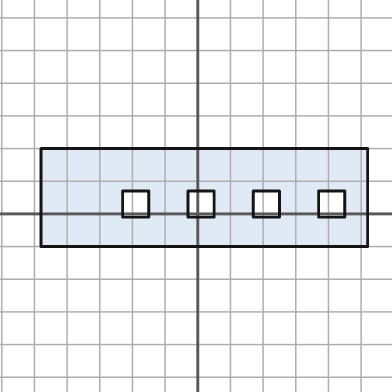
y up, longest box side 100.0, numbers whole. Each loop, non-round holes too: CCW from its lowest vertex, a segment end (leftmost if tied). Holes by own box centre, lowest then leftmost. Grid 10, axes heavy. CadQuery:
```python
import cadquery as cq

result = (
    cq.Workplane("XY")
    .moveTo(-48.0, -10.0)
    .lineTo(52.0, -10.0)
    .lineTo(52.0, 20.0)
    .lineTo(-48.0, 20.0)
    .close()
    .moveTo(-23.0, -1.0)
    .lineTo(-15.0, -1.0)
    .lineTo(-15.0, 7.0)
    .lineTo(-23.0, 7.0)
    .close()
    .moveTo(-3.0, -1.0)
    .lineTo(5.0, -1.0)
    .lineTo(5.0, 7.0)
    .lineTo(-3.0, 7.0)
    .close()
    .moveTo(17.0, -1.0)
    .lineTo(25.0, -1.0)
    .lineTo(25.0, 7.0)
    .lineTo(17.0, 7.0)
    .close()
    .moveTo(37.0, -1.0)
    .lineTo(45.0, -1.0)
    .lineTo(45.0, 7.0)
    .lineTo(37.0, 7.0)
    .close()
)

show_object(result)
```